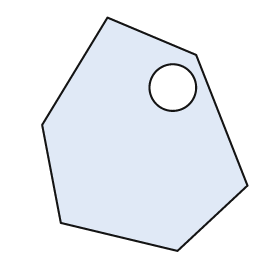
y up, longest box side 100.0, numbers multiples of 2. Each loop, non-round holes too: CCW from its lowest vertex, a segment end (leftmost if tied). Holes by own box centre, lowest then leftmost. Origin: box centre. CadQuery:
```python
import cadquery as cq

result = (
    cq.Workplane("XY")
    .moveTo(14.0, -50.0)
    .lineTo(44.0, -22.0)
    .lineTo(22.0, 34.0)
    .lineTo(-16.0, 50.0)
    .lineTo(-44.0, 4.0)
    .lineTo(-36.0, -38.0)
    .close()
    .moveTo(12.0, 20.0)
    .circle(10.0)
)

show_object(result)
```